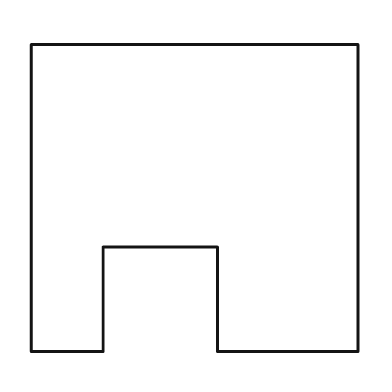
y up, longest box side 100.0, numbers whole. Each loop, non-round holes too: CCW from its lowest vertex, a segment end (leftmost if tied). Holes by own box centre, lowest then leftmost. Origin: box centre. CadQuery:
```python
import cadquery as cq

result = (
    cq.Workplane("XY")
    .moveTo(-50.0, -47.0)
    .lineTo(-28.0, -47.0)
    .lineTo(-28.0, -15.0)
    .lineTo(7.0, -15.0)
    .lineTo(7.0, -47.0)
    .lineTo(50.0, -47.0)
    .lineTo(50.0, 47.0)
    .lineTo(-50.0, 47.0)
    .close()
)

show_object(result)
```